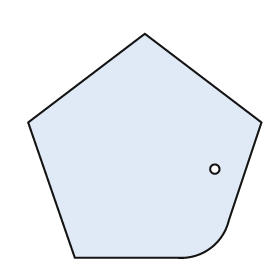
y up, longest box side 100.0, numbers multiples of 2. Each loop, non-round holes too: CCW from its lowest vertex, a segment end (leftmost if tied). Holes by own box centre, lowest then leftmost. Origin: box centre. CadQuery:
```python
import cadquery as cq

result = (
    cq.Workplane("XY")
    .moveTo(-30.0, -48.0)
    .lineTo(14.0, -48.0)
    .threePointArc((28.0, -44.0), (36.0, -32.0))
    .lineTo(50.0, 10.0)
    .lineTo(0.0, 48.0)
    .lineTo(-50.0, 10.0)
    .close()
    .moveTo(30.0, -10.0)
    .circle(2.0)
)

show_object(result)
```